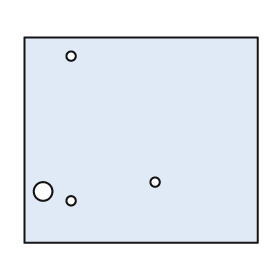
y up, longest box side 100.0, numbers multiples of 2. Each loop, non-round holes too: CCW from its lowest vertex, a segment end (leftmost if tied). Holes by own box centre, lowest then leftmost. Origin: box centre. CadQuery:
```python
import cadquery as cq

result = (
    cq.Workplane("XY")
    .moveTo(-50.0, -44.0)
    .lineTo(50.0, -44.0)
    .lineTo(50.0, 44.0)
    .lineTo(-50.0, 44.0)
    .close()
    .moveTo(-30.0, -26.0)
    .circle(2.0)
    .moveTo(-42.0, -22.0)
    .circle(4.0)
    .moveTo(6.0, -18.0)
    .circle(2.0)
    .moveTo(-30.0, 36.0)
    .circle(2.0)
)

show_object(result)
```